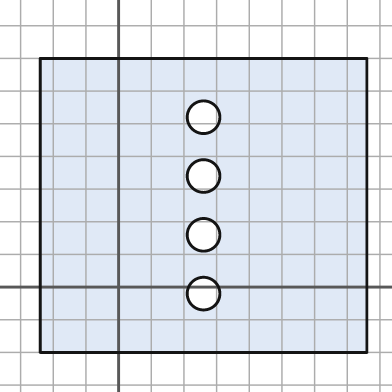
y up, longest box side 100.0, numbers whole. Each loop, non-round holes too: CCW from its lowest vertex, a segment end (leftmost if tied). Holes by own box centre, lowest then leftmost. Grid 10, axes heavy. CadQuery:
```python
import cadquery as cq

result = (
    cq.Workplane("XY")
    .moveTo(-24.0, -20.0)
    .lineTo(76.0, -20.0)
    .lineTo(76.0, 70.0)
    .lineTo(-24.0, 70.0)
    .close()
    .moveTo(26.0, -2.0)
    .circle(5.0)
    .moveTo(26.0, 16.0)
    .circle(5.0)
    .moveTo(26.0, 34.0)
    .circle(5.0)
    .moveTo(26.0, 52.0)
    .circle(5.0)
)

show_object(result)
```